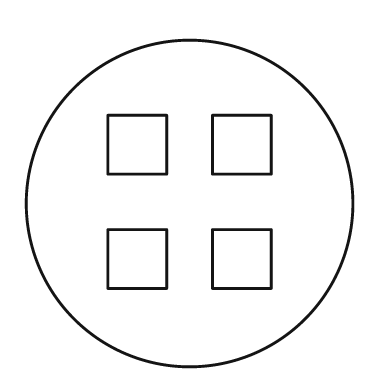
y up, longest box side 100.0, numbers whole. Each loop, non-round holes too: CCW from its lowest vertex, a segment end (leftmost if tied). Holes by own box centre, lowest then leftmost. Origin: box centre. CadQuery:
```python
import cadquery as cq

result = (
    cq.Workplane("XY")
    .moveTo(0.0, 0.0)
    .circle(50.0)
    .moveTo(-25.0, -26.0)
    .lineTo(-7.0, -26.0)
    .lineTo(-7.0, -8.0)
    .lineTo(-25.0, -8.0)
    .close()
    .moveTo(7.0, -26.0)
    .lineTo(25.0, -26.0)
    .lineTo(25.0, -8.0)
    .lineTo(7.0, -8.0)
    .close()
    .moveTo(-25.0, 9.0)
    .lineTo(-7.0, 9.0)
    .lineTo(-7.0, 27.0)
    .lineTo(-25.0, 27.0)
    .close()
    .moveTo(7.0, 9.0)
    .lineTo(25.0, 9.0)
    .lineTo(25.0, 27.0)
    .lineTo(7.0, 27.0)
    .close()
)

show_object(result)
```